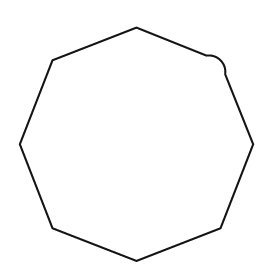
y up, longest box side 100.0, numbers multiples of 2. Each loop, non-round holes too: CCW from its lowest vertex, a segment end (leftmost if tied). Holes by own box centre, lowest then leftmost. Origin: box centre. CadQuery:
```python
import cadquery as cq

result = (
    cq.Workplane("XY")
    .moveTo(0.0, -50.0)
    .lineTo(36.0, -36.0)
    .lineTo(50.0, 0.0)
    .lineTo(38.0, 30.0)
    .threePointArc((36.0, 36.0), (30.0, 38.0))
    .lineTo(0.0, 50.0)
    .lineTo(-36.0, 36.0)
    .lineTo(-50.0, 0.0)
    .lineTo(-36.0, -36.0)
    .close()
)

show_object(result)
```